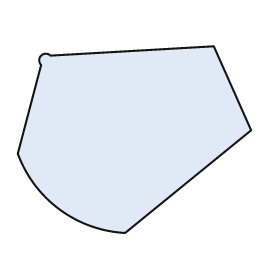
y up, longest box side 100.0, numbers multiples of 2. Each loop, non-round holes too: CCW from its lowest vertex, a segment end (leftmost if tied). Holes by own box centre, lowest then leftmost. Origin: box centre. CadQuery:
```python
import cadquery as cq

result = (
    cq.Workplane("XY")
    .moveTo(-4.0, -40.0)
    .lineTo(50.0, 4.0)
    .lineTo(34.0, 40.0)
    .lineTo(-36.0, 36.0)
    .threePointArc((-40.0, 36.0), (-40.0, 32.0))
    .lineTo(-50.0, -6.0)
    .threePointArc((-32.0, -30.0), (-4.0, -40.0))
    .close()
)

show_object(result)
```